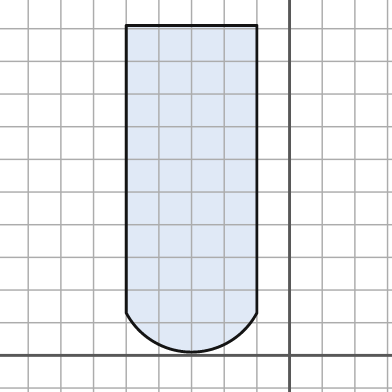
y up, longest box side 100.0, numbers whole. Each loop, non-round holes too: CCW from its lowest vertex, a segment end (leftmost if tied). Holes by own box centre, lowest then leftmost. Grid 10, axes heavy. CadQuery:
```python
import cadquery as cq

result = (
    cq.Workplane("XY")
    .moveTo(-50.0, 13.0)
    .threePointArc((-30.0, 1.0), (-10.0, 13.0))
    .lineTo(-10.0, 101.0)
    .lineTo(-50.0, 101.0)
    .close()
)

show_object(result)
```